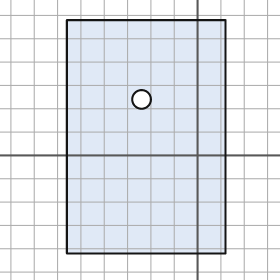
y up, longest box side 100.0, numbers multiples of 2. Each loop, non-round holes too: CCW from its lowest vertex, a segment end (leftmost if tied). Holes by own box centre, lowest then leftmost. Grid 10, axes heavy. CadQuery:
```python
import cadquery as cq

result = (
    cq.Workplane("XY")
    .moveTo(-56.0, -42.0)
    .lineTo(12.0, -42.0)
    .lineTo(12.0, 58.0)
    .lineTo(-56.0, 58.0)
    .close()
    .moveTo(-24.0, 24.0)
    .circle(4.0)
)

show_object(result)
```